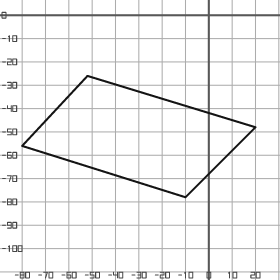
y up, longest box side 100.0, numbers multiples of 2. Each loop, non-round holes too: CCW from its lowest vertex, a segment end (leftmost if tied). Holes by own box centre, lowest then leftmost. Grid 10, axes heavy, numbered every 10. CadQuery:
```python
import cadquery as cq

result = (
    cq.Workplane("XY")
    .moveTo(-10.0, -78.0)
    .lineTo(20.0, -48.0)
    .lineTo(-52.0, -26.0)
    .lineTo(-80.0, -56.0)
    .close()
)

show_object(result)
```